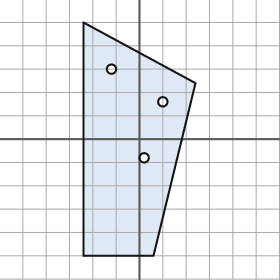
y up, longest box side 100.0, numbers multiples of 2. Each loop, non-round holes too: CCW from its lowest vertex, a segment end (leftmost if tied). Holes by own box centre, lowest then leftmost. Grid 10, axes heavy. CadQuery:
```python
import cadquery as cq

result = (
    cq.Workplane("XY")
    .moveTo(-24.0, -50.0)
    .lineTo(6.0, -50.0)
    .lineTo(24.0, 24.0)
    .lineTo(-24.0, 50.0)
    .close()
    .moveTo(2.0, -8.0)
    .circle(2.0)
    .moveTo(10.0, 16.0)
    .circle(2.0)
    .moveTo(-12.0, 30.0)
    .circle(2.0)
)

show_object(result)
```